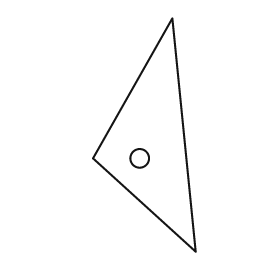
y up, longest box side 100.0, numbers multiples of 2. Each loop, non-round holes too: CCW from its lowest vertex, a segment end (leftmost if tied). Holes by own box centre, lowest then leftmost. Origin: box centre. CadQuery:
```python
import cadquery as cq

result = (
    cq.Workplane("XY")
    .moveTo(22.0, -50.0)
    .lineTo(12.0, 50.0)
    .lineTo(-22.0, -10.0)
    .close()
    .moveTo(-2.0, -10.0)
    .circle(4.0)
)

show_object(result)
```